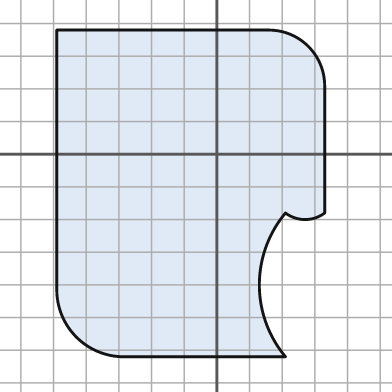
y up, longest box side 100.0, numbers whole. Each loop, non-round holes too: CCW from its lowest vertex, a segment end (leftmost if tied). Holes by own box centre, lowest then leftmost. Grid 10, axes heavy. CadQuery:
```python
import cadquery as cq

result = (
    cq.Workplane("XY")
    .moveTo(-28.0, -62.0)
    .lineTo(21.0, -62.0)
    .threePointArc((13.0, -40.0), (21.0, -18.0))
    .threePointArc((27.0, -20.0), (33.0, -18.0))
    .lineTo(33.0, 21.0)
    .threePointArc((28.0, 33.0), (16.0, 38.0))
    .lineTo(-49.0, 38.0)
    .lineTo(-49.0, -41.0)
    .threePointArc((-43.0, -56.0), (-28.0, -62.0))
    .close()
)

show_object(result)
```